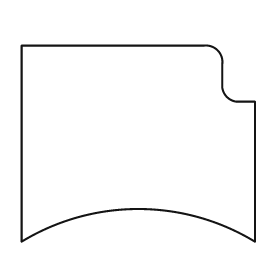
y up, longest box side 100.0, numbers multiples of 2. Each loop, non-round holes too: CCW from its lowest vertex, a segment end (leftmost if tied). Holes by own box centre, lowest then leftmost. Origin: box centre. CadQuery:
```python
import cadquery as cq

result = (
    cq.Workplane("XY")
    .moveTo(-50.0, -42.0)
    .threePointArc((0.0, -28.0), (50.0, -42.0))
    .lineTo(50.0, 18.0)
    .lineTo(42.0, 18.0)
    .threePointArc((38.0, 20.0), (36.0, 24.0))
    .lineTo(36.0, 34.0)
    .threePointArc((34.0, 40.0), (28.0, 42.0))
    .lineTo(-50.0, 42.0)
    .close()
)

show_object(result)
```